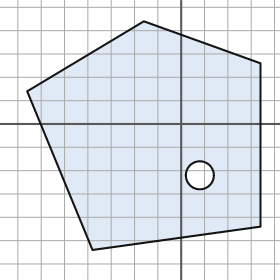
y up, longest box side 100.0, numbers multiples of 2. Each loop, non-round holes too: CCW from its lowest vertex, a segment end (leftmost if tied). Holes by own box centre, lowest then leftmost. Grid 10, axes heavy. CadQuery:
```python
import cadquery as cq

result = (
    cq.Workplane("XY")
    .moveTo(-38.0, -54.0)
    .lineTo(34.0, -44.0)
    .lineTo(34.0, 26.0)
    .lineTo(-16.0, 44.0)
    .lineTo(-66.0, 14.0)
    .close()
    .moveTo(8.0, -22.0)
    .circle(6.0)
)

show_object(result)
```